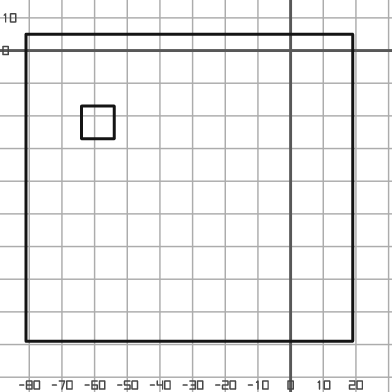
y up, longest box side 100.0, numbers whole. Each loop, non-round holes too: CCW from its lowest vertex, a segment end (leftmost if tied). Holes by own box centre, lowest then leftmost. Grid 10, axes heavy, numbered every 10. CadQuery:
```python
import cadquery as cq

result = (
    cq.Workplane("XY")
    .moveTo(-81.0, -89.0)
    .lineTo(19.0, -89.0)
    .lineTo(19.0, 5.0)
    .lineTo(-81.0, 5.0)
    .close()
    .moveTo(-64.0, -27.0)
    .lineTo(-54.0, -27.0)
    .lineTo(-54.0, -17.0)
    .lineTo(-64.0, -17.0)
    .close()
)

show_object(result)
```